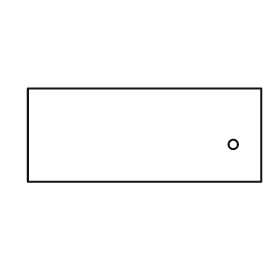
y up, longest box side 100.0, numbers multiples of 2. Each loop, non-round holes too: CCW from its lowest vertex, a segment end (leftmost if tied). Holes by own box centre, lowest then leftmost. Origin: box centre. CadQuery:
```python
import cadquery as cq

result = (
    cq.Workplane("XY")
    .moveTo(-50.0, -20.0)
    .lineTo(50.0, -20.0)
    .lineTo(50.0, 20.0)
    .lineTo(-50.0, 20.0)
    .close()
    .moveTo(38.0, -4.0)
    .circle(2.0)
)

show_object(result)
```